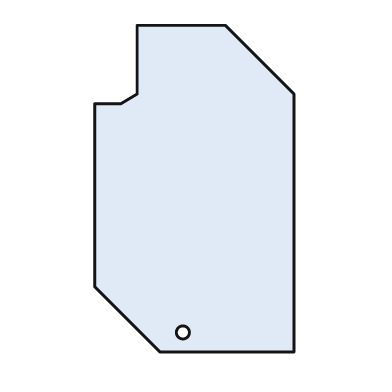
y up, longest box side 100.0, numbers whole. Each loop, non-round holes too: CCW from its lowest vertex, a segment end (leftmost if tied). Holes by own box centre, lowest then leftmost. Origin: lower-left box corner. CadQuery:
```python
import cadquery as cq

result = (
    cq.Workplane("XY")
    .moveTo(20.0, 0.0)
    .lineTo(61.0, 0.0)
    .lineTo(61.0, 79.0)
    .lineTo(40.0, 100.0)
    .lineTo(13.0, 100.0)
    .lineTo(13.0, 79.0)
    .lineTo(8.0, 76.0)
    .lineTo(0.0, 76.0)
    .lineTo(0.0, 20.0)
    .close()
    .moveTo(27.0, 6.0)
    .circle(2.0)
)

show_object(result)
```